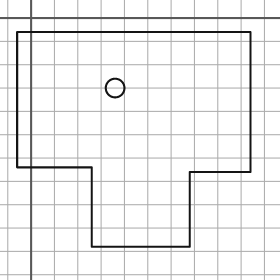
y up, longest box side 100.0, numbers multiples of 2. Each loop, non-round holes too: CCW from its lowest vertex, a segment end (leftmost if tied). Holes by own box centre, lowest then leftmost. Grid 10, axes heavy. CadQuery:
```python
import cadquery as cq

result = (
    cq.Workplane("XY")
    .moveTo(26.0, -98.0)
    .lineTo(68.0, -98.0)
    .lineTo(68.0, -66.0)
    .lineTo(94.0, -66.0)
    .lineTo(94.0, -6.0)
    .lineTo(-6.0, -6.0)
    .lineTo(-6.0, -64.0)
    .lineTo(26.0, -64.0)
    .close()
    .moveTo(36.0, -30.0)
    .circle(4.0)
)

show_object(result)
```